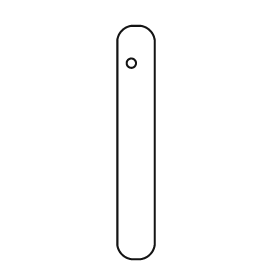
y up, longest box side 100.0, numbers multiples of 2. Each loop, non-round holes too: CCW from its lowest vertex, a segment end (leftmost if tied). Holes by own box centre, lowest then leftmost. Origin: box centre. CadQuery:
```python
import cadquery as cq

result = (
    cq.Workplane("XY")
    .moveTo(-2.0, -50.0)
    .lineTo(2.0, -50.0)
    .threePointArc((6.0, -48.0), (8.0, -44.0))
    .lineTo(8.0, 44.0)
    .threePointArc((6.0, 48.0), (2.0, 50.0))
    .lineTo(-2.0, 50.0)
    .threePointArc((-6.0, 48.0), (-8.0, 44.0))
    .lineTo(-8.0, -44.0)
    .threePointArc((-6.0, -48.0), (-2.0, -50.0))
    .close()
    .moveTo(-2.0, 34.0)
    .circle(2.0)
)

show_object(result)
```